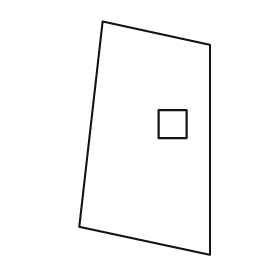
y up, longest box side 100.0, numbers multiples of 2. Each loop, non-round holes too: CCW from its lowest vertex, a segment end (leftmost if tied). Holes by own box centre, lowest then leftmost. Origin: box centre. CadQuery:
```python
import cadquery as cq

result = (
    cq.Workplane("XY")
    .moveTo(28.0, -50.0)
    .lineTo(28.0, 40.0)
    .lineTo(-18.0, 50.0)
    .lineTo(-28.0, -38.0)
    .close()
    .moveTo(6.0, 0.0)
    .lineTo(18.0, 0.0)
    .lineTo(18.0, 12.0)
    .lineTo(6.0, 12.0)
    .close()
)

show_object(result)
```